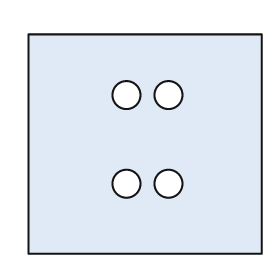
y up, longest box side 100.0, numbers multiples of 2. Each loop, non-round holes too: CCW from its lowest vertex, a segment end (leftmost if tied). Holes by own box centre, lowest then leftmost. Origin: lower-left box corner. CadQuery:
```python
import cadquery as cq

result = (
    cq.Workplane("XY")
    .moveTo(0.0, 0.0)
    .lineTo(100.0, 0.0)
    .lineTo(100.0, 94.0)
    .lineTo(0.0, 94.0)
    .close()
    .moveTo(42.0, 30.0)
    .circle(6.0)
    .moveTo(60.0, 30.0)
    .circle(6.0)
    .moveTo(42.0, 68.0)
    .circle(6.0)
    .moveTo(60.0, 68.0)
    .circle(6.0)
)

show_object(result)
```